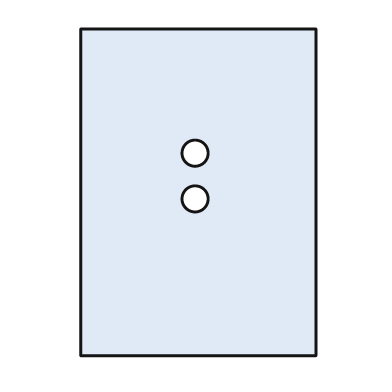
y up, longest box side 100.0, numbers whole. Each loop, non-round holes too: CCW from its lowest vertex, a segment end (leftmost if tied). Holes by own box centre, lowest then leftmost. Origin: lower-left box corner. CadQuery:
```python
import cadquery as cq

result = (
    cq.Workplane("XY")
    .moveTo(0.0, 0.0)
    .lineTo(72.0, 0.0)
    .lineTo(72.0, 100.0)
    .lineTo(0.0, 100.0)
    .close()
    .moveTo(35.0, 48.0)
    .circle(4.0)
    .moveTo(35.0, 62.0)
    .circle(4.0)
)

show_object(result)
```